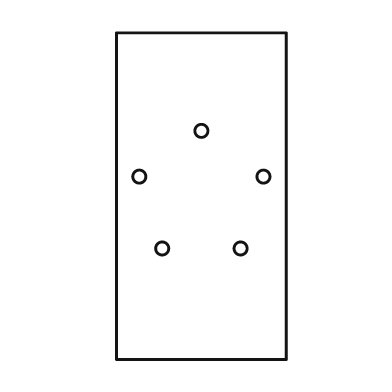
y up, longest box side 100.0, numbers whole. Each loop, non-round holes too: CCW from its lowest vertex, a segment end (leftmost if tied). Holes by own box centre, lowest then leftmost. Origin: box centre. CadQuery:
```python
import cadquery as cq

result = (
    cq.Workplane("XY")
    .moveTo(-26.0, -50.0)
    .lineTo(26.0, -50.0)
    .lineTo(26.0, 50.0)
    .lineTo(-26.0, 50.0)
    .close()
    .moveTo(-12.0, -16.0)
    .circle(2.0)
    .moveTo(12.0, -16.0)
    .circle(2.0)
    .moveTo(-19.0, 6.0)
    .circle(2.0)
    .moveTo(19.0, 6.0)
    .circle(2.0)
    .moveTo(0.0, 20.0)
    .circle(2.0)
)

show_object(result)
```